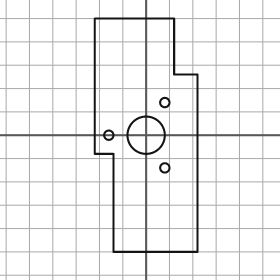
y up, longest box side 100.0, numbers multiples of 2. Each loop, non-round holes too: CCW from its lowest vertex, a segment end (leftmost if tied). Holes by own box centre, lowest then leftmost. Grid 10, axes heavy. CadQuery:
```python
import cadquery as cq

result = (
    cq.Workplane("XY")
    .moveTo(-14.0, -50.0)
    .lineTo(22.0, -50.0)
    .lineTo(22.0, 26.0)
    .lineTo(12.0, 26.0)
    .lineTo(12.0, 50.0)
    .lineTo(-22.0, 50.0)
    .lineTo(-22.0, -8.0)
    .lineTo(-14.0, -8.0)
    .close()
    .moveTo(8.0, -14.0)
    .circle(2.0)
    .moveTo(-16.0, 0.0)
    .circle(2.0)
    .moveTo(0.0, 0.0)
    .circle(8.0)
    .moveTo(8.0, 14.0)
    .circle(2.0)
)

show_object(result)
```